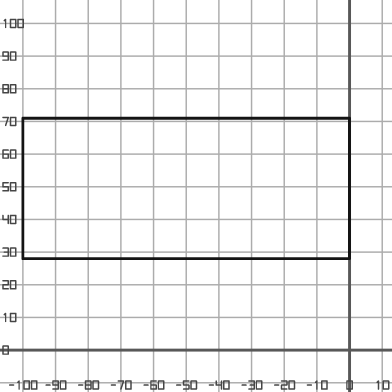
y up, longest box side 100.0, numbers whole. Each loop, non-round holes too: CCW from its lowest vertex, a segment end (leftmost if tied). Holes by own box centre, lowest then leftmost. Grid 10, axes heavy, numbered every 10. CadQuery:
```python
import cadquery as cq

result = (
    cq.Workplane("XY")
    .moveTo(-100.0, 28.0)
    .lineTo(0.0, 28.0)
    .lineTo(0.0, 71.0)
    .lineTo(-100.0, 71.0)
    .close()
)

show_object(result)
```